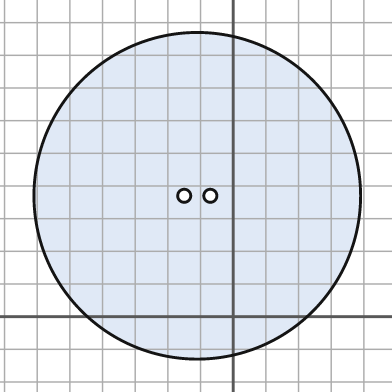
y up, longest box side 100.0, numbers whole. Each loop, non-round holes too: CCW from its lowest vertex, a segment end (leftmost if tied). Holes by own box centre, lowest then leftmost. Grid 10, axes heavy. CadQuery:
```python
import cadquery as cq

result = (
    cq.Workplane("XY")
    .moveTo(-11.0, 37.0)
    .circle(50.0)
    .moveTo(-15.0, 37.0)
    .circle(2.0)
    .moveTo(-7.0, 37.0)
    .circle(2.0)
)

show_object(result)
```